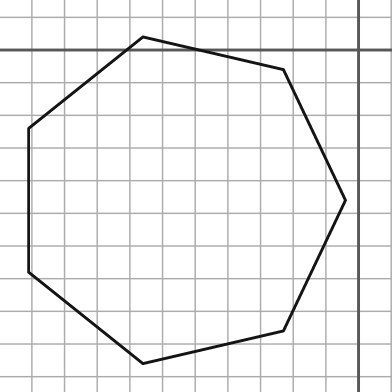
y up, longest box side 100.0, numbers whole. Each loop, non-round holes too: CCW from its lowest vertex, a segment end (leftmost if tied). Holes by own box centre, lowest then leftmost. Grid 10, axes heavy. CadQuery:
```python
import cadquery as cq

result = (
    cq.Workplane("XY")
    .moveTo(-66.0, -96.0)
    .lineTo(-23.0, -86.0)
    .lineTo(-4.0, -46.0)
    .lineTo(-23.0, -6.0)
    .lineTo(-66.0, 4.0)
    .lineTo(-101.0, -24.0)
    .lineTo(-101.0, -68.0)
    .close()
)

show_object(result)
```